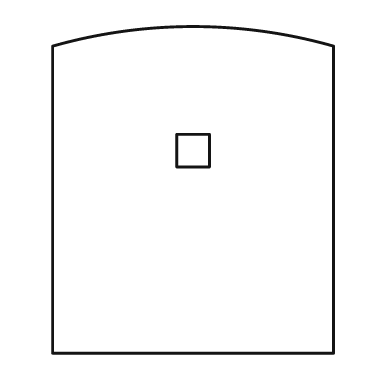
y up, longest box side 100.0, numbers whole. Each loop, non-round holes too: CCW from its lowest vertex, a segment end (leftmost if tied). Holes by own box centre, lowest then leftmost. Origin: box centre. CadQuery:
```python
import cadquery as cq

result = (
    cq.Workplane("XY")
    .moveTo(-43.0, -50.0)
    .lineTo(43.0, -50.0)
    .lineTo(43.0, 44.0)
    .threePointArc((0.0, 50.0), (-43.0, 44.0))
    .close()
    .moveTo(-5.0, 7.0)
    .lineTo(5.0, 7.0)
    .lineTo(5.0, 17.0)
    .lineTo(-5.0, 17.0)
    .close()
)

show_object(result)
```